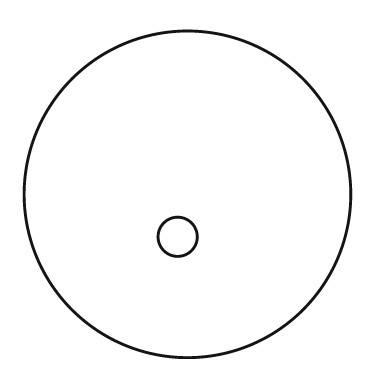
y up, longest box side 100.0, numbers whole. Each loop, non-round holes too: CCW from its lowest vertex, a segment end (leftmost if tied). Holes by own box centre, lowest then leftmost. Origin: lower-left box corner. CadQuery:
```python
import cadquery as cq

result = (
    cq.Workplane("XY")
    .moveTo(50.0, 50.0)
    .circle(50.0)
    .moveTo(47.0, 37.0)
    .circle(6.0)
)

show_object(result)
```